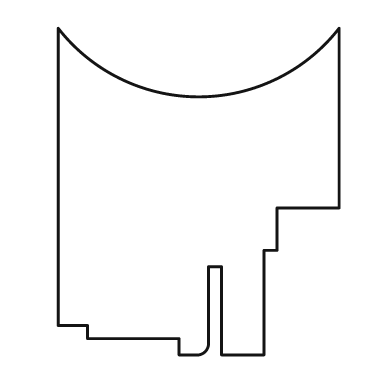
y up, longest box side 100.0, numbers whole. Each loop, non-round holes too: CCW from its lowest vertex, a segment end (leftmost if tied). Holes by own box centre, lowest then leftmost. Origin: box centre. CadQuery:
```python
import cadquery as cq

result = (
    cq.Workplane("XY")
    .moveTo(-6.0, -50.0)
    .lineTo(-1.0, -50.0)
    .threePointArc((2.0, -49.0), (3.0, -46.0))
    .lineTo(3.0, -23.0)
    .lineTo(7.0, -23.0)
    .lineTo(7.0, -50.0)
    .lineTo(20.0, -50.0)
    .lineTo(20.0, -18.0)
    .lineTo(24.0, -18.0)
    .lineTo(24.0, -5.0)
    .lineTo(43.0, -5.0)
    .lineTo(43.0, 50.0)
    .threePointArc((0.0, 29.0), (-43.0, 50.0))
    .lineTo(-43.0, -41.0)
    .lineTo(-34.0, -41.0)
    .lineTo(-34.0, -45.0)
    .lineTo(-6.0, -45.0)
    .close()
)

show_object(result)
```